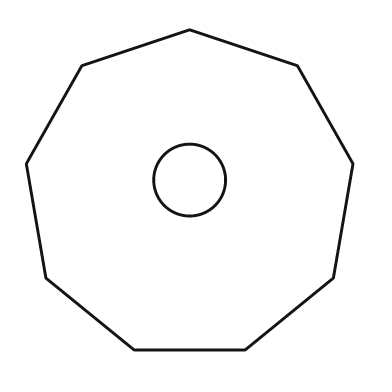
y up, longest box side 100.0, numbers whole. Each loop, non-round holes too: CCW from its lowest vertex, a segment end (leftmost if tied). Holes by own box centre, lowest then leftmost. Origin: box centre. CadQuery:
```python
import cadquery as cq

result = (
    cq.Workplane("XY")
    .moveTo(-17.0, -49.0)
    .lineTo(17.0, -49.0)
    .lineTo(44.0, -27.0)
    .lineTo(50.0, 8.0)
    .lineTo(33.0, 38.0)
    .lineTo(0.0, 49.0)
    .lineTo(-33.0, 38.0)
    .lineTo(-50.0, 8.0)
    .lineTo(-44.0, -27.0)
    .close()
    .moveTo(0.0, 3.0)
    .circle(11.0)
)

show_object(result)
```